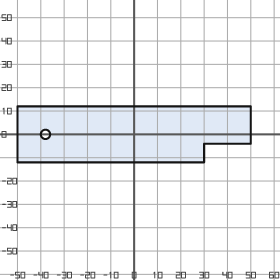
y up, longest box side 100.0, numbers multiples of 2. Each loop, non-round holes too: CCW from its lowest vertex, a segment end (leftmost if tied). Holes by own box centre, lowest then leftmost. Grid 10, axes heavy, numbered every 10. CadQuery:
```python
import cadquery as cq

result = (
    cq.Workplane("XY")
    .moveTo(-50.0, -12.0)
    .lineTo(30.0, -12.0)
    .lineTo(30.0, -4.0)
    .lineTo(50.0, -4.0)
    .lineTo(50.0, 12.0)
    .lineTo(-50.0, 12.0)
    .close()
    .moveTo(-38.0, 0.0)
    .circle(2.0)
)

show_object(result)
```